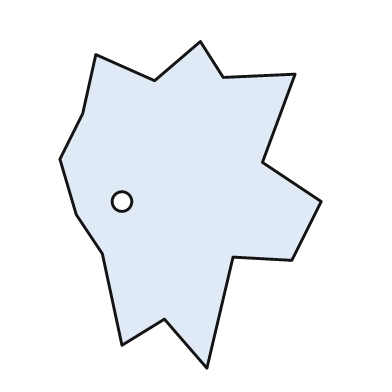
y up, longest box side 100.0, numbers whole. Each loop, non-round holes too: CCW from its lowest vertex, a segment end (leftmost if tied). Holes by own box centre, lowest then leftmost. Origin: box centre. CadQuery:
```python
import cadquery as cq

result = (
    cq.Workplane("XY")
    .moveTo(5.0, -50.0)
    .lineTo(13.0, -16.0)
    .lineTo(31.0, -17.0)
    .lineTo(40.0, 1.0)
    .lineTo(22.0, 13.0)
    .lineTo(32.0, 40.0)
    .lineTo(10.0, 39.0)
    .lineTo(3.0, 50.0)
    .lineTo(-11.0, 38.0)
    .lineTo(-29.0, 46.0)
    .lineTo(-33.0, 28.0)
    .lineTo(-40.0, 14.0)
    .lineTo(-35.0, -3.0)
    .lineTo(-27.0, -15.0)
    .lineTo(-21.0, -43.0)
    .lineTo(-8.0, -35.0)
    .close()
    .moveTo(-21.0, 1.0)
    .circle(3.0)
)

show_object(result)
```